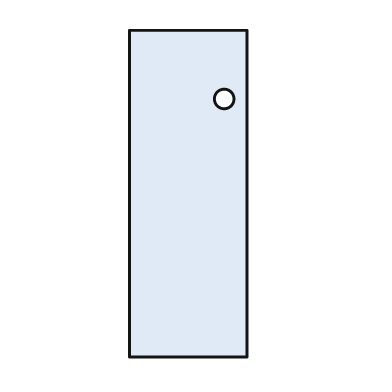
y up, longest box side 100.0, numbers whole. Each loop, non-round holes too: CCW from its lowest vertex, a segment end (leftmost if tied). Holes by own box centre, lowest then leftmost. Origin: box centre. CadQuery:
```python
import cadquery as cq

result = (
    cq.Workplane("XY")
    .moveTo(-18.0, -50.0)
    .lineTo(18.0, -50.0)
    .lineTo(18.0, 50.0)
    .lineTo(-18.0, 50.0)
    .close()
    .moveTo(11.0, 29.0)
    .circle(3.0)
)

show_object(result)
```